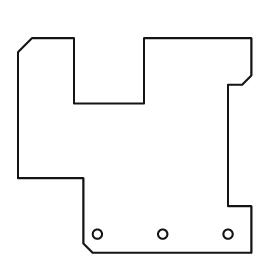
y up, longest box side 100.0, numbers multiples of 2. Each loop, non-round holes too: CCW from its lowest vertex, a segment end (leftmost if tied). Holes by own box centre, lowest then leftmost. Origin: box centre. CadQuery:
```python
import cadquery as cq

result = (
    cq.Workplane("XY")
    .moveTo(-18.0, -46.0)
    .lineTo(50.0, -46.0)
    .lineTo(50.0, -26.0)
    .lineTo(40.0, -26.0)
    .lineTo(40.0, 26.0)
    .lineTo(46.0, 26.0)
    .lineTo(50.0, 30.0)
    .lineTo(50.0, 46.0)
    .lineTo(4.0, 46.0)
    .lineTo(4.0, 18.0)
    .lineTo(-26.0, 18.0)
    .lineTo(-26.0, 46.0)
    .lineTo(-44.0, 46.0)
    .lineTo(-50.0, 40.0)
    .lineTo(-50.0, -14.0)
    .lineTo(-22.0, -14.0)
    .lineTo(-22.0, -42.0)
    .close()
    .moveTo(-16.0, -38.0)
    .circle(2.0)
    .moveTo(12.0, -38.0)
    .circle(2.0)
    .moveTo(40.0, -38.0)
    .circle(2.0)
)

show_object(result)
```